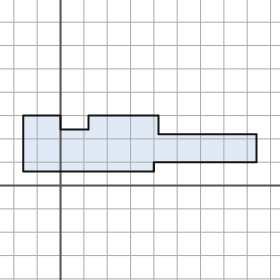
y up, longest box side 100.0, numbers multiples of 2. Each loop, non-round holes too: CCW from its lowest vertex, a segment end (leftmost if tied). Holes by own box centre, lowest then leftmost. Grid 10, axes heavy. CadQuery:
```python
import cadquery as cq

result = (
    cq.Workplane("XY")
    .moveTo(-16.0, 6.0)
    .lineTo(40.0, 6.0)
    .lineTo(40.0, 10.0)
    .lineTo(84.0, 10.0)
    .lineTo(84.0, 22.0)
    .lineTo(42.0, 22.0)
    .lineTo(42.0, 30.0)
    .lineTo(12.0, 30.0)
    .lineTo(12.0, 24.0)
    .lineTo(0.0, 24.0)
    .lineTo(0.0, 30.0)
    .lineTo(-16.0, 30.0)
    .close()
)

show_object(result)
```